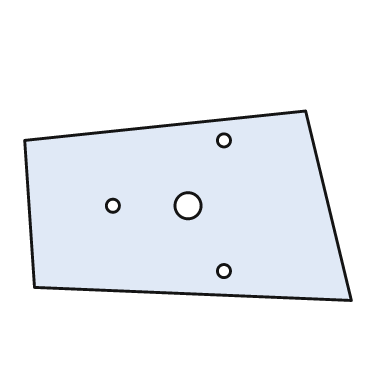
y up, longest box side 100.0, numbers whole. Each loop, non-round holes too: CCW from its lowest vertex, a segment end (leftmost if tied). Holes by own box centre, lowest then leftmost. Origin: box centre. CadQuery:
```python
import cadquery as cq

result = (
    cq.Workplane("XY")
    .moveTo(50.0, -29.0)
    .lineTo(36.0, 29.0)
    .lineTo(-50.0, 20.0)
    .lineTo(-47.0, -25.0)
    .close()
    .moveTo(11.0, -20.0)
    .circle(2.0)
    .moveTo(-23.0, 0.0)
    .circle(2.0)
    .moveTo(0.0, 0.0)
    .circle(4.0)
    .moveTo(11.0, 20.0)
    .circle(2.0)
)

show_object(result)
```